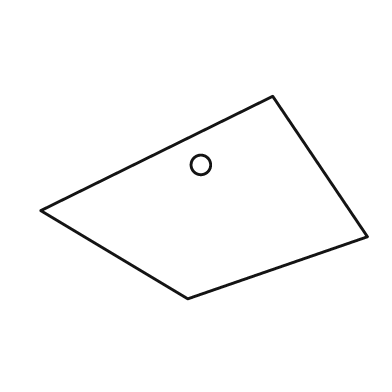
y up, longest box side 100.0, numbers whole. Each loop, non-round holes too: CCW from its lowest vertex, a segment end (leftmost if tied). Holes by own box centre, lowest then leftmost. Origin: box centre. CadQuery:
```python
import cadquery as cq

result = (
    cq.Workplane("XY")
    .moveTo(-5.0, -31.0)
    .lineTo(50.0, -12.0)
    .lineTo(21.0, 31.0)
    .lineTo(-50.0, -4.0)
    .close()
    .moveTo(-1.0, 10.0)
    .circle(3.0)
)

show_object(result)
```